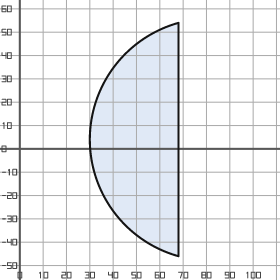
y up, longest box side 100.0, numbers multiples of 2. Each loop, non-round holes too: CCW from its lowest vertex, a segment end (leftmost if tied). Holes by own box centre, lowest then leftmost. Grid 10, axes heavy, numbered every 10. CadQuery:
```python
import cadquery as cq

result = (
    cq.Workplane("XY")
    .moveTo(68.0, -46.0)
    .lineTo(68.0, 54.0)
    .threePointArc((30.0, 4.0), (68.0, -46.0))
    .close()
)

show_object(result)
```